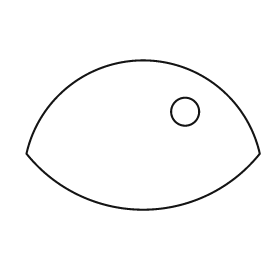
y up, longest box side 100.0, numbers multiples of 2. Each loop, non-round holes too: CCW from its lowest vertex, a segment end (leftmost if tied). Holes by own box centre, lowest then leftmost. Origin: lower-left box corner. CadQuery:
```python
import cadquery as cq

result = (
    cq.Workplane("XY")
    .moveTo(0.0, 24.0)
    .threePointArc((50.0, 0.0), (100.0, 24.0))
    .threePointArc((50.0, 64.0), (0.0, 24.0))
    .close()
    .moveTo(68.0, 42.0)
    .circle(6.0)
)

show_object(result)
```